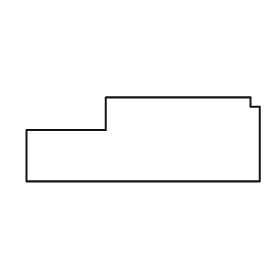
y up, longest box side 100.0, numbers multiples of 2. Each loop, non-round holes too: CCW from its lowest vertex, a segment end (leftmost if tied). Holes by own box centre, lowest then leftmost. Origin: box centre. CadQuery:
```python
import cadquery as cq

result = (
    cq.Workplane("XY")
    .moveTo(-50.0, -18.0)
    .lineTo(50.0, -18.0)
    .lineTo(50.0, 14.0)
    .lineTo(46.0, 14.0)
    .lineTo(46.0, 18.0)
    .lineTo(-16.0, 18.0)
    .lineTo(-16.0, 4.0)
    .lineTo(-50.0, 4.0)
    .close()
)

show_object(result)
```